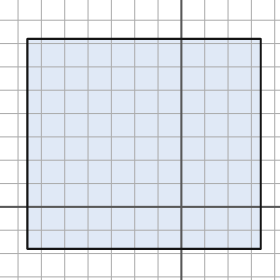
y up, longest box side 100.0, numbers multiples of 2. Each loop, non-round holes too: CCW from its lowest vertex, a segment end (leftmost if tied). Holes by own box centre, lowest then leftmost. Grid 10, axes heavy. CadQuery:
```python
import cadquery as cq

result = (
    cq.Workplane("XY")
    .moveTo(-66.0, -18.0)
    .lineTo(34.0, -18.0)
    .lineTo(34.0, 72.0)
    .lineTo(-66.0, 72.0)
    .close()
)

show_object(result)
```